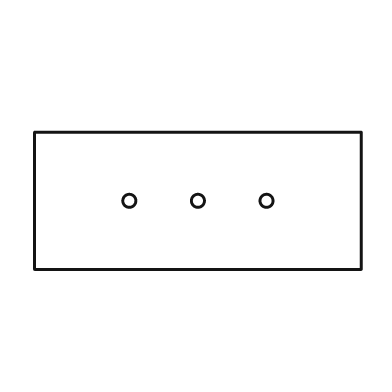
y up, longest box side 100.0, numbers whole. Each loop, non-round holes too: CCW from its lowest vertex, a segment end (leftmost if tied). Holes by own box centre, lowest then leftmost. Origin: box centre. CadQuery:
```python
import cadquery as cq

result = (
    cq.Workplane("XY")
    .moveTo(-50.0, -21.0)
    .lineTo(50.0, -21.0)
    .lineTo(50.0, 21.0)
    .lineTo(-50.0, 21.0)
    .close()
    .moveTo(-21.0, 0.0)
    .circle(2.0)
    .moveTo(0.0, 0.0)
    .circle(2.0)
    .moveTo(21.0, 0.0)
    .circle(2.0)
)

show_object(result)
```